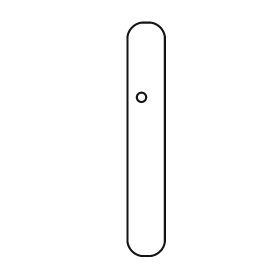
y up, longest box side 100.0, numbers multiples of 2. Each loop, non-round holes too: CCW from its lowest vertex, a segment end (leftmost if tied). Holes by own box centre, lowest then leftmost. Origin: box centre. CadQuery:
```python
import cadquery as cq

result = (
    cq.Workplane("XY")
    .moveTo(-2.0, -50.0)
    .lineTo(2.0, -50.0)
    .threePointArc((6.0, -48.0), (8.0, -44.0))
    .lineTo(8.0, 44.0)
    .threePointArc((6.0, 48.0), (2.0, 50.0))
    .lineTo(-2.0, 50.0)
    .threePointArc((-6.0, 48.0), (-8.0, 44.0))
    .lineTo(-8.0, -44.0)
    .threePointArc((-6.0, -48.0), (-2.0, -50.0))
    .close()
    .moveTo(-2.0, 18.0)
    .circle(2.0)
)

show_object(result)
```